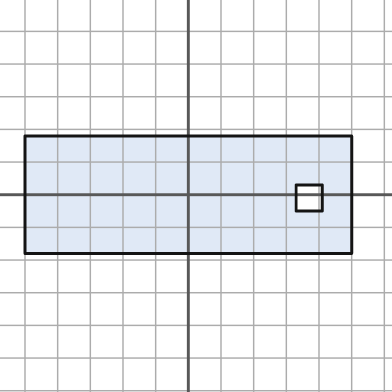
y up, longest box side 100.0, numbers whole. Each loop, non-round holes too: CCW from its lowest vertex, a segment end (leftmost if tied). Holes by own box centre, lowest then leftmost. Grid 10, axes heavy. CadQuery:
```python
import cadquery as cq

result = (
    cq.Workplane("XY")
    .moveTo(-50.0, -18.0)
    .lineTo(50.0, -18.0)
    .lineTo(50.0, 18.0)
    .lineTo(-50.0, 18.0)
    .close()
    .moveTo(33.0, -5.0)
    .lineTo(41.0, -5.0)
    .lineTo(41.0, 3.0)
    .lineTo(33.0, 3.0)
    .close()
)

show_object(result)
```